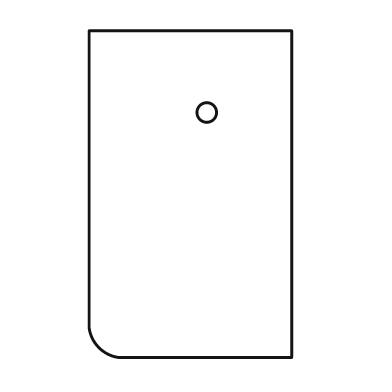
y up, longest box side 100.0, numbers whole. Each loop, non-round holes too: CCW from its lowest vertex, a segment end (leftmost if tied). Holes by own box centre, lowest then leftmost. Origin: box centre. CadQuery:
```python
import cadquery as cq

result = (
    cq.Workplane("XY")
    .moveTo(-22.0, -50.0)
    .lineTo(31.0, -50.0)
    .lineTo(31.0, 50.0)
    .lineTo(-31.0, 50.0)
    .lineTo(-31.0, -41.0)
    .threePointArc((-28.0, -47.0), (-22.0, -50.0))
    .close()
    .moveTo(5.0, 25.0)
    .circle(3.0)
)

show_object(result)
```